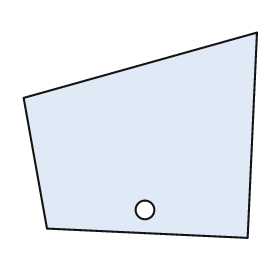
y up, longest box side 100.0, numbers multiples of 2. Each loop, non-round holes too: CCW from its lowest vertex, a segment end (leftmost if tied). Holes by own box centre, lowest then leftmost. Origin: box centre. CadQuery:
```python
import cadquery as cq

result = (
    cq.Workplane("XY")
    .moveTo(46.0, -44.0)
    .lineTo(50.0, 44.0)
    .lineTo(-50.0, 16.0)
    .lineTo(-40.0, -40.0)
    .close()
    .moveTo(2.0, -32.0)
    .circle(4.0)
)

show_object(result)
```